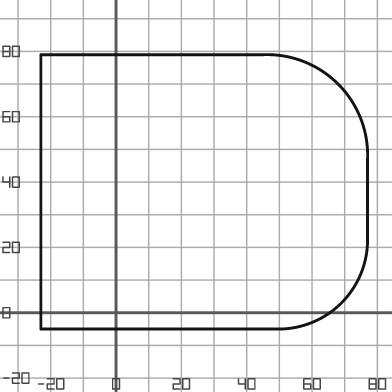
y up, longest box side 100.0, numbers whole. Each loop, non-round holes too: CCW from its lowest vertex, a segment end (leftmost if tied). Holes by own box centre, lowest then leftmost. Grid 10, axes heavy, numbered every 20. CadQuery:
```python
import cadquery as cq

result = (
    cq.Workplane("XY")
    .moveTo(-23.0, -5.0)
    .lineTo(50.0, -5.0)
    .threePointArc((69.0, 3.0), (77.0, 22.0))
    .lineTo(77.0, 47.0)
    .threePointArc((68.0, 70.0), (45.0, 79.0))
    .lineTo(-23.0, 79.0)
    .close()
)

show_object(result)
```